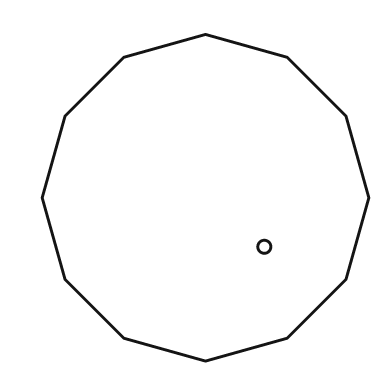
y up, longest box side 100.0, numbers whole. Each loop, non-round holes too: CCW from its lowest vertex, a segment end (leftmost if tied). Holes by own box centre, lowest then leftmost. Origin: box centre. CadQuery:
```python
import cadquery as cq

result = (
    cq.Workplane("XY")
    .moveTo(0.0, -50.0)
    .lineTo(25.0, -43.0)
    .lineTo(43.0, -25.0)
    .lineTo(50.0, 0.0)
    .lineTo(43.0, 25.0)
    .lineTo(25.0, 43.0)
    .lineTo(0.0, 50.0)
    .lineTo(-25.0, 43.0)
    .lineTo(-43.0, 25.0)
    .lineTo(-50.0, 0.0)
    .lineTo(-43.0, -25.0)
    .lineTo(-25.0, -43.0)
    .close()
    .moveTo(18.0, -15.0)
    .circle(2.0)
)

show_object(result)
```